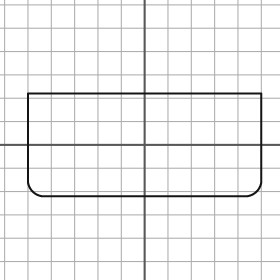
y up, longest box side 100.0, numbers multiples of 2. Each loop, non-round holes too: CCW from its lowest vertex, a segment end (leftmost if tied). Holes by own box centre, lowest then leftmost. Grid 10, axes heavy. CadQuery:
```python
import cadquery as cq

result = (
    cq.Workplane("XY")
    .moveTo(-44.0, -22.0)
    .lineTo(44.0, -22.0)
    .threePointArc((48.0, -20.0), (50.0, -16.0))
    .lineTo(50.0, 22.0)
    .lineTo(-50.0, 22.0)
    .lineTo(-50.0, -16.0)
    .threePointArc((-48.0, -20.0), (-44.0, -22.0))
    .close()
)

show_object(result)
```